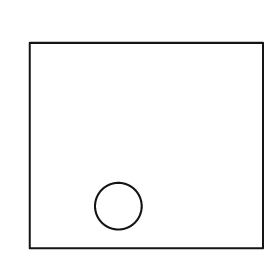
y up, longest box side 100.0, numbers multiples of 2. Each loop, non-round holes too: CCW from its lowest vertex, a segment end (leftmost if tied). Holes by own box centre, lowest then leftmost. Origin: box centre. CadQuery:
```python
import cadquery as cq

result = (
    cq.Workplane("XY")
    .moveTo(-50.0, -44.0)
    .lineTo(50.0, -44.0)
    .lineTo(50.0, 44.0)
    .lineTo(-50.0, 44.0)
    .close()
    .moveTo(-12.0, -26.0)
    .circle(10.0)
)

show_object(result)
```